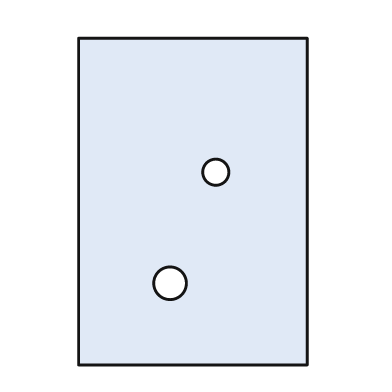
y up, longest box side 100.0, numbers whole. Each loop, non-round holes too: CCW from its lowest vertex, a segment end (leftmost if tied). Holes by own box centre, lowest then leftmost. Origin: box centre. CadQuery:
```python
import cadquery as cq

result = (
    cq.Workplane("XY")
    .moveTo(-35.0, -50.0)
    .lineTo(35.0, -50.0)
    .lineTo(35.0, 50.0)
    .lineTo(-35.0, 50.0)
    .close()
    .moveTo(-7.0, -25.0)
    .circle(5.0)
    .moveTo(7.0, 9.0)
    .circle(4.0)
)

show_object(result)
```